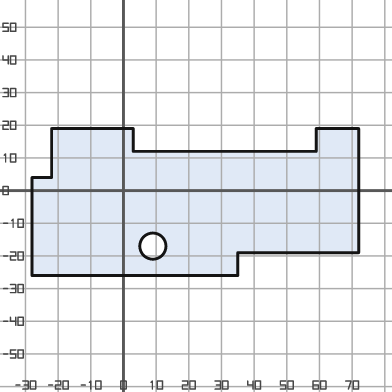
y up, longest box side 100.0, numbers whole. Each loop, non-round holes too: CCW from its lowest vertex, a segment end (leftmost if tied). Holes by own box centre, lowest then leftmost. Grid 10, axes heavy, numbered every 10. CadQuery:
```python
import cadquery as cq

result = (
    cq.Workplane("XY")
    .moveTo(-28.0, -26.0)
    .lineTo(35.0, -26.0)
    .lineTo(35.0, -19.0)
    .lineTo(72.0, -19.0)
    .lineTo(72.0, 19.0)
    .lineTo(59.0, 19.0)
    .lineTo(59.0, 12.0)
    .lineTo(3.0, 12.0)
    .lineTo(3.0, 19.0)
    .lineTo(-22.0, 19.0)
    .lineTo(-22.0, 4.0)
    .lineTo(-28.0, 4.0)
    .close()
    .moveTo(9.0, -17.0)
    .circle(4.0)
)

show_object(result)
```